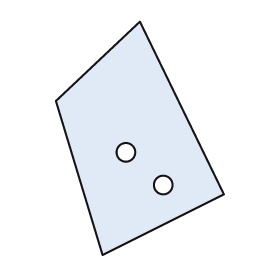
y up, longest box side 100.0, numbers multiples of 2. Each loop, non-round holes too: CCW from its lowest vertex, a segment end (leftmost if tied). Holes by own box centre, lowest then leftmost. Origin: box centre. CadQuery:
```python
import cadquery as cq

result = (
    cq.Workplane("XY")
    .moveTo(-16.0, -50.0)
    .lineTo(36.0, -24.0)
    .lineTo(0.0, 50.0)
    .lineTo(-36.0, 16.0)
    .close()
    .moveTo(10.0, -20.0)
    .circle(4.0)
    .moveTo(-6.0, -6.0)
    .circle(4.0)
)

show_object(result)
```